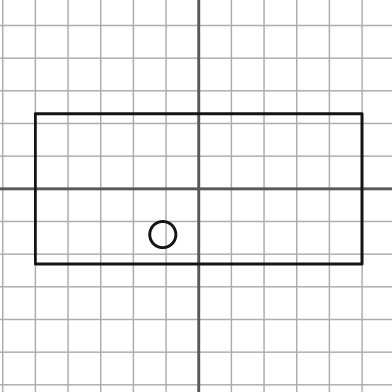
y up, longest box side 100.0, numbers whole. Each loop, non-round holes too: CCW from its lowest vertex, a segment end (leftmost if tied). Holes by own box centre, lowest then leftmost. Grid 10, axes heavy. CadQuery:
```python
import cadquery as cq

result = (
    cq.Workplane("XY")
    .moveTo(-50.0, -23.0)
    .lineTo(50.0, -23.0)
    .lineTo(50.0, 23.0)
    .lineTo(-50.0, 23.0)
    .close()
    .moveTo(-11.0, -14.0)
    .circle(4.0)
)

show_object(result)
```